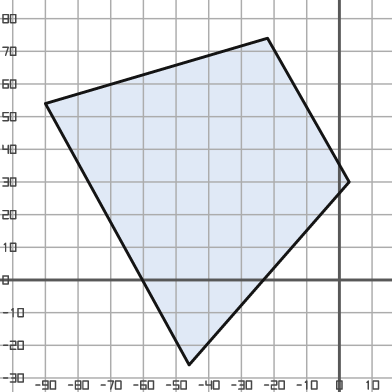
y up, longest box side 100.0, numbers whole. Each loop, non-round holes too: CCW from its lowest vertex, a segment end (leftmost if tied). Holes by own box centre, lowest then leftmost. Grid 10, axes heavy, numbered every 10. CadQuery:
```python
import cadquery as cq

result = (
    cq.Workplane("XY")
    .moveTo(-46.0, -26.0)
    .lineTo(3.0, 30.0)
    .lineTo(-22.0, 74.0)
    .lineTo(-90.0, 54.0)
    .close()
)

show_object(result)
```